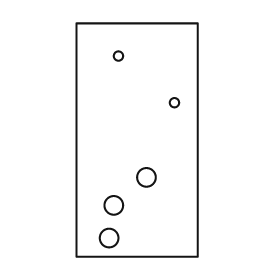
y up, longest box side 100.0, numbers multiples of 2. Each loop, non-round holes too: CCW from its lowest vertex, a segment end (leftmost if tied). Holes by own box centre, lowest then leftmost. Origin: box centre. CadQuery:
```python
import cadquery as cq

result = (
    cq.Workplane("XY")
    .moveTo(-26.0, -50.0)
    .lineTo(26.0, -50.0)
    .lineTo(26.0, 50.0)
    .lineTo(-26.0, 50.0)
    .close()
    .moveTo(-12.0, -42.0)
    .circle(4.0)
    .moveTo(-10.0, -28.0)
    .circle(4.0)
    .moveTo(4.0, -16.0)
    .circle(4.0)
    .moveTo(16.0, 16.0)
    .circle(2.0)
    .moveTo(-8.0, 36.0)
    .circle(2.0)
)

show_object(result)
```